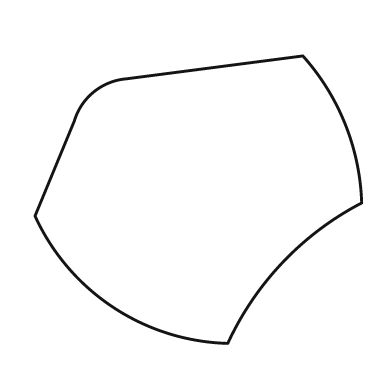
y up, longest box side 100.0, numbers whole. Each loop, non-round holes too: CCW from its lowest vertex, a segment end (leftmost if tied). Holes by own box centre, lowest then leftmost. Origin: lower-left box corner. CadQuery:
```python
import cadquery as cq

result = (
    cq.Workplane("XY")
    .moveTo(59.0, 0.0)
    .threePointArc((76.0, 25.0), (100.0, 43.0))
    .threePointArc((95.0, 67.0), (82.0, 88.0))
    .lineTo(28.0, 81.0)
    .threePointArc((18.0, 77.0), (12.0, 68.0))
    .lineTo(0.0, 39.0)
    .threePointArc((24.0, 11.0), (59.0, 0.0))
    .close()
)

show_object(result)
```